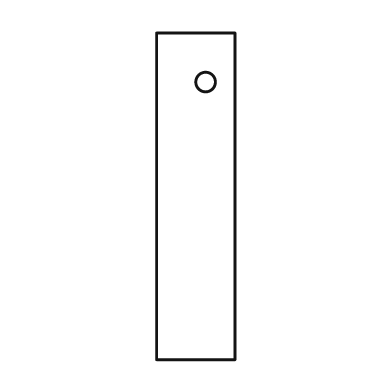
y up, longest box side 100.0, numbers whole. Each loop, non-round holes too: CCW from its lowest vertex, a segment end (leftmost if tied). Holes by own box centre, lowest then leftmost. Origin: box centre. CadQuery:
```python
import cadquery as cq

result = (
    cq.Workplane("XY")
    .moveTo(-12.0, -50.0)
    .lineTo(12.0, -50.0)
    .lineTo(12.0, 50.0)
    .lineTo(-12.0, 50.0)
    .close()
    .moveTo(3.0, 35.0)
    .circle(3.0)
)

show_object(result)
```